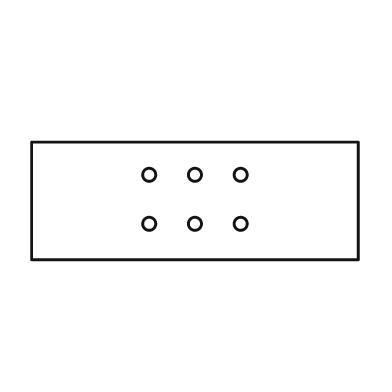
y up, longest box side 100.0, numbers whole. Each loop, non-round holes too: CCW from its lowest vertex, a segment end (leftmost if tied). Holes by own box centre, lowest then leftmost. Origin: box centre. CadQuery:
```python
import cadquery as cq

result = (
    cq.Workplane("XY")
    .moveTo(-50.0, -18.0)
    .lineTo(50.0, -18.0)
    .lineTo(50.0, 18.0)
    .lineTo(-50.0, 18.0)
    .close()
    .moveTo(-14.0, -7.0)
    .circle(2.0)
    .moveTo(0.0, -7.0)
    .circle(2.0)
    .moveTo(14.0, -7.0)
    .circle(2.0)
    .moveTo(-14.0, 8.0)
    .circle(2.0)
    .moveTo(0.0, 8.0)
    .circle(2.0)
    .moveTo(14.0, 8.0)
    .circle(2.0)
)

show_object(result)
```